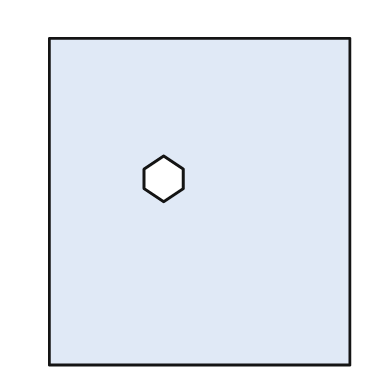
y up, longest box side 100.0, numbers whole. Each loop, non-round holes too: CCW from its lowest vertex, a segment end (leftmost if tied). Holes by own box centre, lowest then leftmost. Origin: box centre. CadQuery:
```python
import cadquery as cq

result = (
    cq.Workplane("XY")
    .moveTo(-46.0, -50.0)
    .lineTo(46.0, -50.0)
    .lineTo(46.0, 50.0)
    .lineTo(-46.0, 50.0)
    .close()
    .moveTo(-11.0, 0.0)
    .lineTo(-5.0, 4.0)
    .lineTo(-5.0, 10.0)
    .lineTo(-11.0, 14.0)
    .lineTo(-17.0, 10.0)
    .lineTo(-17.0, 4.0)
    .close()
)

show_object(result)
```